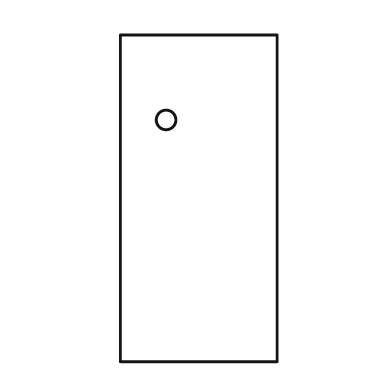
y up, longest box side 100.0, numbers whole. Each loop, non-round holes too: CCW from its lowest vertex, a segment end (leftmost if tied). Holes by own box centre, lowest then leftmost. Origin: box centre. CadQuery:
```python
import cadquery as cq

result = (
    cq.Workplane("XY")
    .moveTo(-24.0, -50.0)
    .lineTo(24.0, -50.0)
    .lineTo(24.0, 50.0)
    .lineTo(-24.0, 50.0)
    .close()
    .moveTo(-10.0, 24.0)
    .circle(3.0)
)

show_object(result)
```